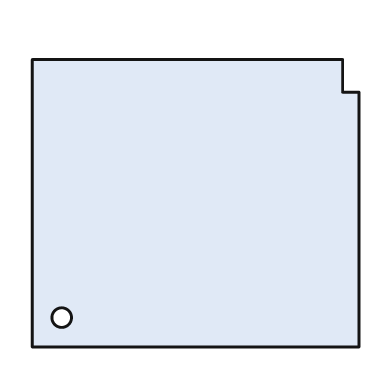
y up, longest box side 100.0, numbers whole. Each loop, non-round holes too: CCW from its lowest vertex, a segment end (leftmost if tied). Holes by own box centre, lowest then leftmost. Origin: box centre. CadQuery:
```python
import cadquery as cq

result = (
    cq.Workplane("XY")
    .moveTo(-50.0, -44.0)
    .lineTo(50.0, -44.0)
    .lineTo(50.0, 34.0)
    .lineTo(45.0, 34.0)
    .lineTo(45.0, 44.0)
    .lineTo(-50.0, 44.0)
    .close()
    .moveTo(-41.0, -35.0)
    .circle(3.0)
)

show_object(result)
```